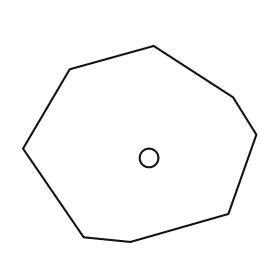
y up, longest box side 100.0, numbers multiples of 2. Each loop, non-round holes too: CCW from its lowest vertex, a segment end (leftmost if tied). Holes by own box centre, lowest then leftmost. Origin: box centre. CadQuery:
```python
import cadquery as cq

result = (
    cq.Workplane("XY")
    .moveTo(-4.0, -42.0)
    .lineTo(38.0, -30.0)
    .lineTo(50.0, 4.0)
    .lineTo(40.0, 20.0)
    .lineTo(6.0, 42.0)
    .lineTo(-30.0, 32.0)
    .lineTo(-50.0, -2.0)
    .lineTo(-24.0, -40.0)
    .close()
    .moveTo(4.0, -6.0)
    .circle(4.0)
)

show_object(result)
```